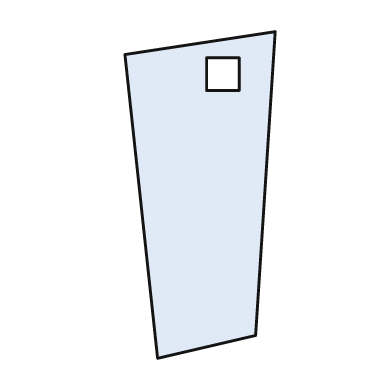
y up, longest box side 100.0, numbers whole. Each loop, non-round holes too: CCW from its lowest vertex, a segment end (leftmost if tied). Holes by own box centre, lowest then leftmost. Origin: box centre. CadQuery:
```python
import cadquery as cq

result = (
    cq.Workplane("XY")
    .moveTo(-13.0, -50.0)
    .lineTo(17.0, -43.0)
    .lineTo(23.0, 50.0)
    .lineTo(-23.0, 43.0)
    .close()
    .moveTo(2.0, 32.0)
    .lineTo(12.0, 32.0)
    .lineTo(12.0, 42.0)
    .lineTo(2.0, 42.0)
    .close()
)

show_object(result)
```